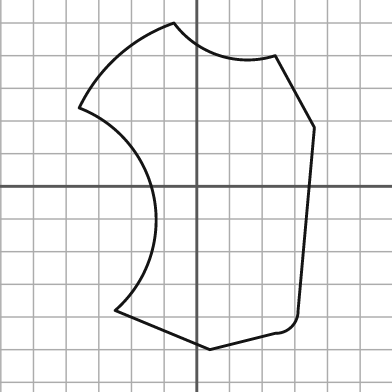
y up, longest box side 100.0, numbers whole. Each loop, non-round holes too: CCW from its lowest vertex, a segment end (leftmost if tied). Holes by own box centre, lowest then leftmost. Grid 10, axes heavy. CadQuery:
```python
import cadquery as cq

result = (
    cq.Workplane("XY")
    .moveTo(4.0, -50.0)
    .lineTo(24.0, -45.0)
    .threePointArc((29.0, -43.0), (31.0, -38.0))
    .lineTo(36.0, 18.0)
    .lineTo(24.0, 40.0)
    .threePointArc((7.0, 40.0), (-7.0, 50.0))
    .threePointArc((-24.0, 40.0), (-36.0, 24.0))
    .threePointArc((-13.0, -4.0), (-25.0, -38.0))
    .close()
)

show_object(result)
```